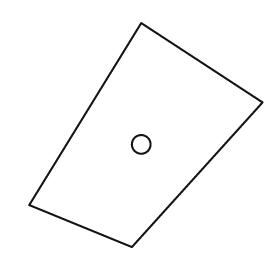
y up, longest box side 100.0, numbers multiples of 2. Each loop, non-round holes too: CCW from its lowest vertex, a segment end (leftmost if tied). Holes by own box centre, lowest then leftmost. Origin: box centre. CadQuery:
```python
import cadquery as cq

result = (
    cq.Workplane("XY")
    .moveTo(-6.0, -48.0)
    .lineTo(50.0, 14.0)
    .lineTo(-2.0, 48.0)
    .lineTo(-50.0, -30.0)
    .close()
    .moveTo(-2.0, -4.0)
    .circle(4.0)
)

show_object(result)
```